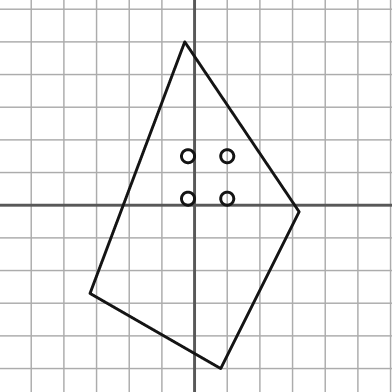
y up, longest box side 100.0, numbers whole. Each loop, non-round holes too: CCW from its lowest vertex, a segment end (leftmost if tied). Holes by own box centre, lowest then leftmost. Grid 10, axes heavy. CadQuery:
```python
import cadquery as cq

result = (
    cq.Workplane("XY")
    .moveTo(8.0, -50.0)
    .lineTo(32.0, -2.0)
    .lineTo(-3.0, 50.0)
    .lineTo(-32.0, -27.0)
    .close()
    .moveTo(-2.0, 2.0)
    .circle(2.0)
    .moveTo(10.0, 2.0)
    .circle(2.0)
    .moveTo(-2.0, 15.0)
    .circle(2.0)
    .moveTo(10.0, 15.0)
    .circle(2.0)
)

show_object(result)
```